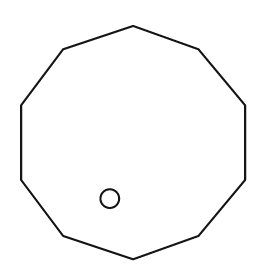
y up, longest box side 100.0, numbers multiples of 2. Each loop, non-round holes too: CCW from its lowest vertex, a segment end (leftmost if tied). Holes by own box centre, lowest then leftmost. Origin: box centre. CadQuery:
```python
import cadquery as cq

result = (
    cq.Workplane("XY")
    .moveTo(0.0, -50.0)
    .lineTo(28.0, -40.0)
    .lineTo(48.0, -16.0)
    .lineTo(48.0, 16.0)
    .lineTo(28.0, 40.0)
    .lineTo(0.0, 50.0)
    .lineTo(-30.0, 40.0)
    .lineTo(-48.0, 16.0)
    .lineTo(-48.0, -16.0)
    .lineTo(-30.0, -40.0)
    .close()
    .moveTo(-10.0, -24.0)
    .circle(4.0)
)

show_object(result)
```